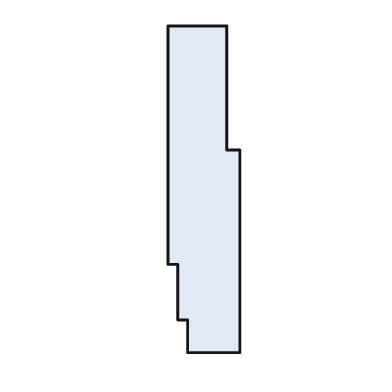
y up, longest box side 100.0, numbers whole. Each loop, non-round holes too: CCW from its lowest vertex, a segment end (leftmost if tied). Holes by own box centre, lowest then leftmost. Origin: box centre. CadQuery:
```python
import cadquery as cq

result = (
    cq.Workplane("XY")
    .moveTo(-5.0, -50.0)
    .lineTo(11.0, -50.0)
    .lineTo(11.0, 12.0)
    .lineTo(7.0, 12.0)
    .lineTo(7.0, 50.0)
    .lineTo(-11.0, 50.0)
    .lineTo(-11.0, -23.0)
    .lineTo(-8.0, -23.0)
    .lineTo(-8.0, -40.0)
    .lineTo(-5.0, -40.0)
    .close()
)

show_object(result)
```